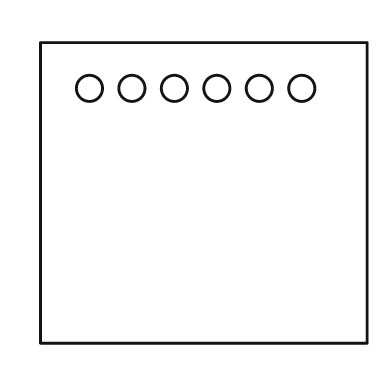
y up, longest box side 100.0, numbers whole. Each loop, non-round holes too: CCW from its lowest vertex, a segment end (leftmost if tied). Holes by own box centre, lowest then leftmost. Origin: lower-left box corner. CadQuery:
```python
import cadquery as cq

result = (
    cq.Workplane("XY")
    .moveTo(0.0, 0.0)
    .lineTo(100.0, 0.0)
    .lineTo(100.0, 92.0)
    .lineTo(0.0, 92.0)
    .close()
    .moveTo(15.0, 78.0)
    .circle(4.0)
    .moveTo(28.0, 78.0)
    .circle(4.0)
    .moveTo(41.0, 78.0)
    .circle(4.0)
    .moveTo(54.0, 78.0)
    .circle(4.0)
    .moveTo(67.0, 78.0)
    .circle(4.0)
    .moveTo(80.0, 78.0)
    .circle(4.0)
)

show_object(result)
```